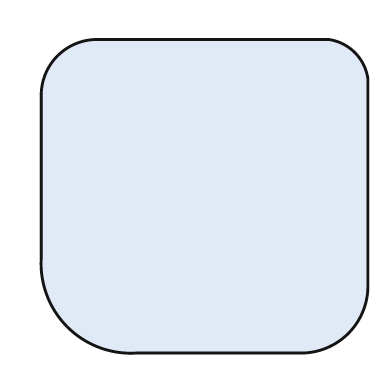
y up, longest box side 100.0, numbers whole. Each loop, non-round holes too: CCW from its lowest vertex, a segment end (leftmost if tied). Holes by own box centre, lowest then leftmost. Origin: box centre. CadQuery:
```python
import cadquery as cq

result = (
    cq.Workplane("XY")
    .moveTo(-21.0, -48.0)
    .lineTo(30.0, -48.0)
    .threePointArc((44.0, -42.0), (50.0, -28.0))
    .lineTo(50.0, 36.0)
    .threePointArc((46.0, 44.0), (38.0, 48.0))
    .lineTo(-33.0, 48.0)
    .threePointArc((-45.0, 43.0), (-50.0, 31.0))
    .lineTo(-50.0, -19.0)
    .threePointArc((-42.0, -40.0), (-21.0, -48.0))
    .close()
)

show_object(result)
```